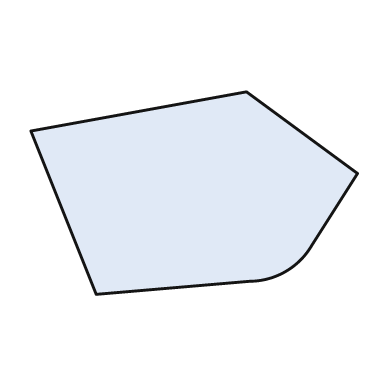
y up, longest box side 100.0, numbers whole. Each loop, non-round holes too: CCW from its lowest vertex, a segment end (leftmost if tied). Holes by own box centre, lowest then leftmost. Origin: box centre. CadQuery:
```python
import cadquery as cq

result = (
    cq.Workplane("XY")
    .moveTo(-30.0, -31.0)
    .lineTo(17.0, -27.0)
    .threePointArc((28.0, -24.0), (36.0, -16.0))
    .lineTo(50.0, 6.0)
    .lineTo(16.0, 31.0)
    .lineTo(-50.0, 19.0)
    .close()
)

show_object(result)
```